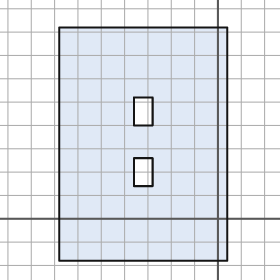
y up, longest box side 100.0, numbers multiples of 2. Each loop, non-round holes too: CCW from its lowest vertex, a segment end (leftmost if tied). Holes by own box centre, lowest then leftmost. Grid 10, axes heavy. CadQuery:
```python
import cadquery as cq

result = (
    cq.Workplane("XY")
    .moveTo(-68.0, -18.0)
    .lineTo(4.0, -18.0)
    .lineTo(4.0, 82.0)
    .lineTo(-68.0, 82.0)
    .close()
    .moveTo(-36.0, 14.0)
    .lineTo(-28.0, 14.0)
    .lineTo(-28.0, 26.0)
    .lineTo(-36.0, 26.0)
    .close()
    .moveTo(-36.0, 40.0)
    .lineTo(-28.0, 40.0)
    .lineTo(-28.0, 52.0)
    .lineTo(-36.0, 52.0)
    .close()
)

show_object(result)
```